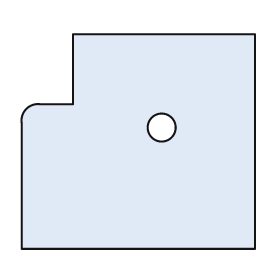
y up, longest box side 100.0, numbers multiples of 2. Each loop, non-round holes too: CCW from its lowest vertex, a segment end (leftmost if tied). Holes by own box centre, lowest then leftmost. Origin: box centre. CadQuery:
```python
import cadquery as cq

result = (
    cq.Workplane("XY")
    .moveTo(-50.0, -46.0)
    .lineTo(50.0, -46.0)
    .lineTo(50.0, 46.0)
    .lineTo(-28.0, 46.0)
    .lineTo(-28.0, 16.0)
    .lineTo(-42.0, 16.0)
    .threePointArc((-48.0, 14.0), (-50.0, 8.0))
    .close()
    .moveTo(10.0, 6.0)
    .circle(6.0)
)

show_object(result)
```